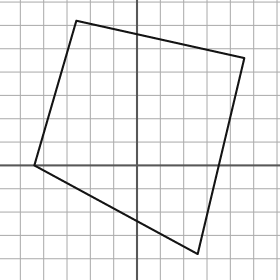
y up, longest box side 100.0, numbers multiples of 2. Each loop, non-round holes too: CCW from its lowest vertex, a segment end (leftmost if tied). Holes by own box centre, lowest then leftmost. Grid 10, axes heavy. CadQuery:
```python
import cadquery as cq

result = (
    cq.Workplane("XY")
    .moveTo(26.0, -38.0)
    .lineTo(46.0, 46.0)
    .lineTo(-26.0, 62.0)
    .lineTo(-44.0, 0.0)
    .close()
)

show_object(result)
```